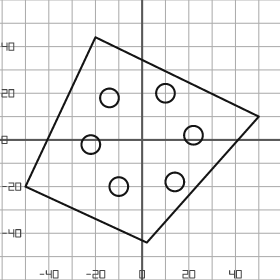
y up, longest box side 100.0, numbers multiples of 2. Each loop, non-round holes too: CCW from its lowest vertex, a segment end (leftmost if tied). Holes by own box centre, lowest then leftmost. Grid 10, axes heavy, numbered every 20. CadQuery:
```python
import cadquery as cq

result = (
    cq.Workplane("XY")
    .moveTo(2.0, -44.0)
    .lineTo(50.0, 10.0)
    .lineTo(-20.0, 44.0)
    .lineTo(-50.0, -20.0)
    .close()
    .moveTo(-10.0, -20.0)
    .circle(4.0)
    .moveTo(14.0, -18.0)
    .circle(4.0)
    .moveTo(-22.0, -2.0)
    .circle(4.0)
    .moveTo(22.0, 2.0)
    .circle(4.0)
    .moveTo(-14.0, 18.0)
    .circle(4.0)
    .moveTo(10.0, 20.0)
    .circle(4.0)
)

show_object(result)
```